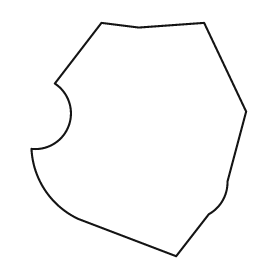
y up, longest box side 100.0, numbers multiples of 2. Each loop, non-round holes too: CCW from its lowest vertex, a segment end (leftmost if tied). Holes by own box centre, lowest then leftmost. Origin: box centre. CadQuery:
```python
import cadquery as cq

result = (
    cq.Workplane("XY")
    .moveTo(16.0, -50.0)
    .lineTo(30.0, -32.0)
    .threePointArc((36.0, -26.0), (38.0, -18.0))
    .lineTo(46.0, 12.0)
    .lineTo(28.0, 50.0)
    .lineTo(0.0, 48.0)
    .lineTo(-16.0, 50.0)
    .lineTo(-36.0, 24.0)
    .threePointArc((-30.0, 6.0), (-46.0, -4.0))
    .threePointArc((-40.0, -22.0), (-26.0, -34.0))
    .close()
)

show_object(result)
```